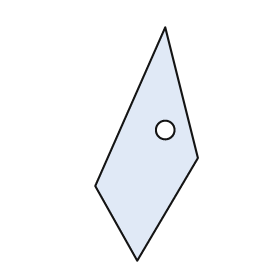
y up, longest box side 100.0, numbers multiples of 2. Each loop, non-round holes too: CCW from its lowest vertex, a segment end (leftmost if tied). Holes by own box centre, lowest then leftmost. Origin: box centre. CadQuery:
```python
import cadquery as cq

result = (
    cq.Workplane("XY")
    .moveTo(-4.0, -50.0)
    .lineTo(22.0, -6.0)
    .lineTo(8.0, 50.0)
    .lineTo(-22.0, -18.0)
    .close()
    .moveTo(8.0, 6.0)
    .circle(4.0)
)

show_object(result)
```